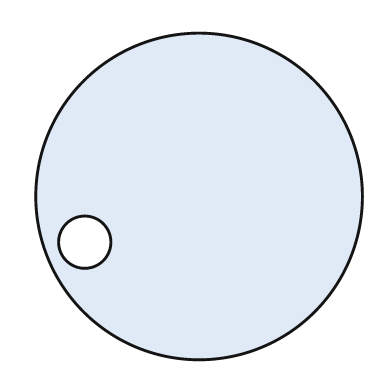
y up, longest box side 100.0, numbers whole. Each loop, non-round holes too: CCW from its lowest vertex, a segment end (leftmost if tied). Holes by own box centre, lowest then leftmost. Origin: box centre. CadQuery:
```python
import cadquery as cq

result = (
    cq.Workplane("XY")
    .moveTo(0.0, 0.0)
    .circle(50.0)
    .moveTo(-35.0, -14.0)
    .circle(8.0)
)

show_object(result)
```